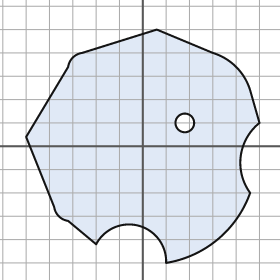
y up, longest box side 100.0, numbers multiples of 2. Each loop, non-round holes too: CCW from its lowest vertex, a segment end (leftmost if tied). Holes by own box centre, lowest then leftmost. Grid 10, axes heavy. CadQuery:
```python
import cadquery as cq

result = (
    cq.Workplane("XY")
    .moveTo(10.0, -50.0)
    .threePointArc((32.0, -40.0), (46.0, -20.0))
    .threePointArc((42.0, -4.0), (50.0, 10.0))
    .lineTo(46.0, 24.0)
    .threePointArc((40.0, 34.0), (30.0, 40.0))
    .lineTo(6.0, 50.0)
    .lineTo(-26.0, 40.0)
    .threePointArc((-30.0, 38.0), (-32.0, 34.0))
    .lineTo(-50.0, 4.0)
    .lineTo(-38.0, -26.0)
    .threePointArc((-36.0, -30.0), (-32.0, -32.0))
    .lineTo(-20.0, -42.0)
    .threePointArc((-2.0, -34.0), (10.0, -50.0))
    .close()
    .moveTo(18.0, 10.0)
    .circle(4.0)
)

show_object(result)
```